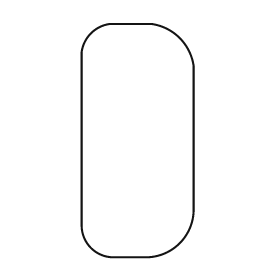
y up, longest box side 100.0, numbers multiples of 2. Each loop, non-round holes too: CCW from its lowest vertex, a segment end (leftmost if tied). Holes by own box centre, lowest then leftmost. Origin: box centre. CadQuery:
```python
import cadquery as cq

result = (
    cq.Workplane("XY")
    .moveTo(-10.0, -50.0)
    .lineTo(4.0, -50.0)
    .threePointArc((18.0, -44.0), (24.0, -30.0))
    .lineTo(24.0, 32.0)
    .threePointArc((18.0, 44.0), (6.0, 50.0))
    .lineTo(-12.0, 50.0)
    .threePointArc((-20.0, 46.0), (-24.0, 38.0))
    .lineTo(-24.0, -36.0)
    .threePointArc((-20.0, -46.0), (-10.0, -50.0))
    .close()
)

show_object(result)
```